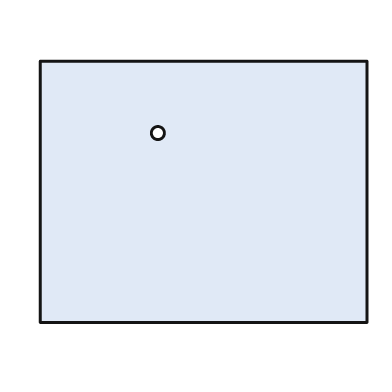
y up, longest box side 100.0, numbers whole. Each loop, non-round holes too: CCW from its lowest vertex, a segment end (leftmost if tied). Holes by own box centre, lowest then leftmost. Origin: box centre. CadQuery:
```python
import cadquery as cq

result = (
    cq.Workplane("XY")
    .moveTo(-50.0, -40.0)
    .lineTo(50.0, -40.0)
    .lineTo(50.0, 40.0)
    .lineTo(-50.0, 40.0)
    .close()
    .moveTo(-14.0, 18.0)
    .circle(2.0)
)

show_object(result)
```